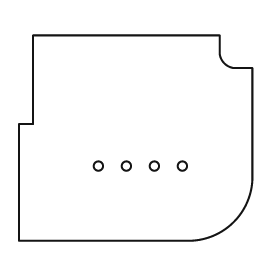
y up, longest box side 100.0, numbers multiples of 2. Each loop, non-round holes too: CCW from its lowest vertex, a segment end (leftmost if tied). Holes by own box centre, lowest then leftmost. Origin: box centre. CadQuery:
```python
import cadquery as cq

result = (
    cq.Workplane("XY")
    .moveTo(-50.0, -44.0)
    .lineTo(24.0, -44.0)
    .threePointArc((42.0, -36.0), (50.0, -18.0))
    .lineTo(50.0, 30.0)
    .lineTo(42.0, 30.0)
    .threePointArc((38.0, 32.0), (36.0, 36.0))
    .lineTo(36.0, 44.0)
    .lineTo(-44.0, 44.0)
    .lineTo(-44.0, 6.0)
    .lineTo(-50.0, 6.0)
    .close()
    .moveTo(-16.0, -12.0)
    .circle(2.0)
    .moveTo(-4.0, -12.0)
    .circle(2.0)
    .moveTo(8.0, -12.0)
    .circle(2.0)
    .moveTo(20.0, -12.0)
    .circle(2.0)
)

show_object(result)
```